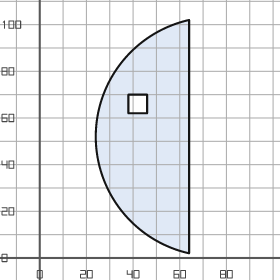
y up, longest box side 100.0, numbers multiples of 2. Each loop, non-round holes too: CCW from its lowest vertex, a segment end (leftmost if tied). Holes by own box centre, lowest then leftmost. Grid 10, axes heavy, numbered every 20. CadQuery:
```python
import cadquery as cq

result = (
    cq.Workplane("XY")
    .moveTo(64.0, 2.0)
    .lineTo(64.0, 102.0)
    .threePointArc((24.0, 52.0), (64.0, 2.0))
    .close()
    .moveTo(38.0, 62.0)
    .lineTo(46.0, 62.0)
    .lineTo(46.0, 70.0)
    .lineTo(38.0, 70.0)
    .close()
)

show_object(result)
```